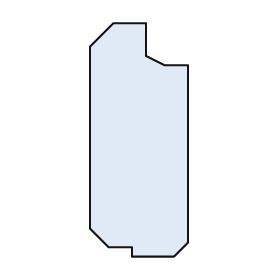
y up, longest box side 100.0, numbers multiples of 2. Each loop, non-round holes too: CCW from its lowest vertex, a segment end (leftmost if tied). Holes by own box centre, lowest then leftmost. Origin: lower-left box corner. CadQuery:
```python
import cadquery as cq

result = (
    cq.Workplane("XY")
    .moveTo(18.0, 0.0)
    .lineTo(36.0, 0.0)
    .lineTo(42.0, 6.0)
    .lineTo(42.0, 82.0)
    .lineTo(32.0, 82.0)
    .lineTo(24.0, 86.0)
    .lineTo(24.0, 100.0)
    .lineTo(10.0, 100.0)
    .lineTo(0.0, 90.0)
    .lineTo(0.0, 12.0)
    .lineTo(8.0, 4.0)
    .lineTo(18.0, 4.0)
    .close()
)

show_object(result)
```